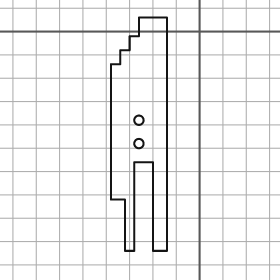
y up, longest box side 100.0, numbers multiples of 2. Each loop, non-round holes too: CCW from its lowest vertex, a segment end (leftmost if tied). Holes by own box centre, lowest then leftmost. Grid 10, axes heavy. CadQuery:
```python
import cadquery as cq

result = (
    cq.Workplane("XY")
    .moveTo(-32.0, -94.0)
    .lineTo(-28.0, -94.0)
    .lineTo(-28.0, -56.0)
    .lineTo(-20.0, -56.0)
    .lineTo(-20.0, -94.0)
    .lineTo(-14.0, -94.0)
    .lineTo(-14.0, 6.0)
    .lineTo(-26.0, 6.0)
    .lineTo(-26.0, -2.0)
    .lineTo(-30.0, -2.0)
    .lineTo(-30.0, -8.0)
    .lineTo(-34.0, -8.0)
    .lineTo(-34.0, -14.0)
    .lineTo(-38.0, -14.0)
    .lineTo(-38.0, -72.0)
    .lineTo(-32.0, -72.0)
    .close()
    .moveTo(-26.0, -48.0)
    .circle(2.0)
    .moveTo(-26.0, -38.0)
    .circle(2.0)
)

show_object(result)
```